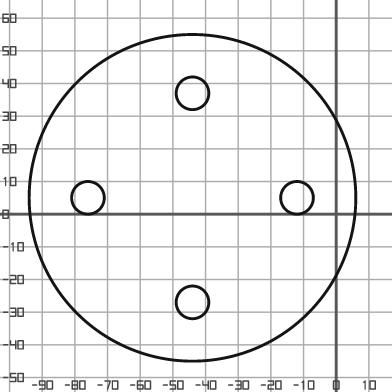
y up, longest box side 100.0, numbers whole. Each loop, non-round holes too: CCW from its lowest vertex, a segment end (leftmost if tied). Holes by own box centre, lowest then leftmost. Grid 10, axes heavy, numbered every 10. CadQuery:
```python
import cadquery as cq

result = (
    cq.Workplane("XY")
    .moveTo(-44.0, 5.0)
    .circle(50.0)
    .moveTo(-44.0, -27.0)
    .circle(5.0)
    .moveTo(-76.0, 5.0)
    .circle(5.0)
    .moveTo(-12.0, 5.0)
    .circle(5.0)
    .moveTo(-44.0, 37.0)
    .circle(5.0)
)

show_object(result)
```